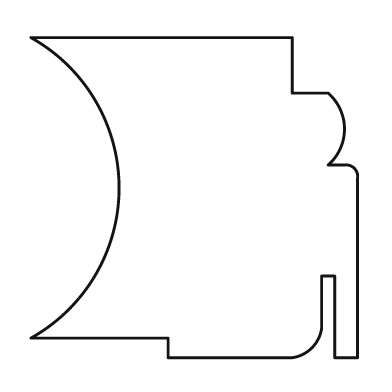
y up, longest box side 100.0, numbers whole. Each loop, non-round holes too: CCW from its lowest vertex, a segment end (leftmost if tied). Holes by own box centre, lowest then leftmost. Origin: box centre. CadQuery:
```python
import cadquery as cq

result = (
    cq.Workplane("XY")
    .moveTo(-8.0, -49.0)
    .lineTo(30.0, -49.0)
    .threePointArc((36.0, -46.0), (39.0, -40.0))
    .lineTo(39.0, -24.0)
    .lineTo(43.0, -24.0)
    .lineTo(43.0, -49.0)
    .lineTo(50.0, -49.0)
    .lineTo(50.0, 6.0)
    .threePointArc((49.0, 9.0), (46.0, 10.0))
    .lineTo(41.0, 10.0)
    .threePointArc((46.0, 21.0), (41.0, 32.0))
    .lineTo(30.0, 32.0)
    .lineTo(30.0, 49.0)
    .lineTo(-50.0, 49.0)
    .threePointArc((-23.0, 3.0), (-50.0, -43.0))
    .lineTo(-8.0, -43.0)
    .close()
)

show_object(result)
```